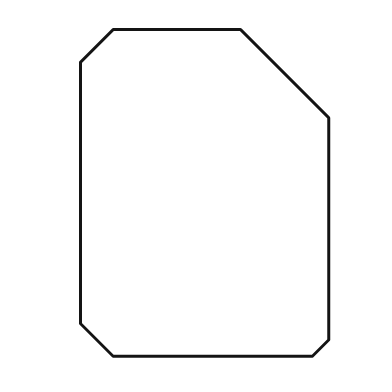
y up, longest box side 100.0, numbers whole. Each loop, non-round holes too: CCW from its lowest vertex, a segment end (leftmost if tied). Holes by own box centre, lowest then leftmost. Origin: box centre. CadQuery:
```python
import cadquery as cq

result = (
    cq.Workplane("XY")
    .moveTo(-28.0, -50.0)
    .lineTo(33.0, -50.0)
    .lineTo(38.0, -45.0)
    .lineTo(38.0, 23.0)
    .lineTo(11.0, 50.0)
    .lineTo(-28.0, 50.0)
    .lineTo(-38.0, 40.0)
    .lineTo(-38.0, -40.0)
    .close()
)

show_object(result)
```